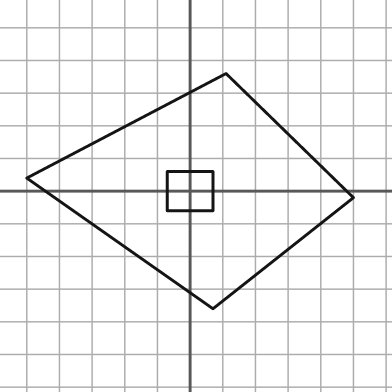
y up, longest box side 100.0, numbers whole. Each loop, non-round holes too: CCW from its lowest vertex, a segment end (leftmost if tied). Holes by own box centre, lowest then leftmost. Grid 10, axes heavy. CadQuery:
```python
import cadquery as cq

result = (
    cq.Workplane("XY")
    .moveTo(7.0, -36.0)
    .lineTo(50.0, -2.0)
    .lineTo(11.0, 36.0)
    .lineTo(-50.0, 4.0)
    .close()
    .moveTo(-7.0, -6.0)
    .lineTo(7.0, -6.0)
    .lineTo(7.0, 6.0)
    .lineTo(-7.0, 6.0)
    .close()
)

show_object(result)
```